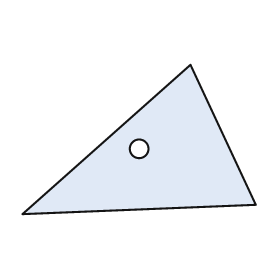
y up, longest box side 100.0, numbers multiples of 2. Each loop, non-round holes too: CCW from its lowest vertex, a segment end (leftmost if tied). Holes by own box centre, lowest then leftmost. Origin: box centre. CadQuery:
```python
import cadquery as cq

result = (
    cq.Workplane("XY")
    .moveTo(-50.0, -32.0)
    .lineTo(50.0, -28.0)
    .lineTo(22.0, 32.0)
    .close()
    .moveTo(0.0, -4.0)
    .circle(4.0)
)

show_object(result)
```